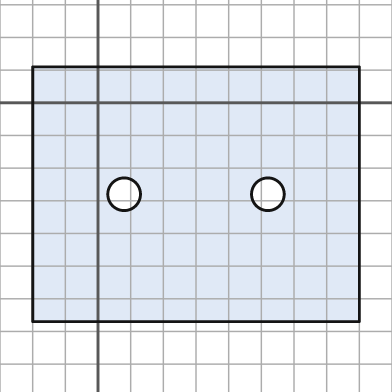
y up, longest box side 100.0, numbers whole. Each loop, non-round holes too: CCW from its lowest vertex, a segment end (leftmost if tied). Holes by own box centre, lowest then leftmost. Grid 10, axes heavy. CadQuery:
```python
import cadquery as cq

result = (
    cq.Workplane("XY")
    .moveTo(-20.0, -67.0)
    .lineTo(80.0, -67.0)
    .lineTo(80.0, 11.0)
    .lineTo(-20.0, 11.0)
    .close()
    .moveTo(8.0, -28.0)
    .circle(5.0)
    .moveTo(52.0, -28.0)
    .circle(5.0)
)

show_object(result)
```